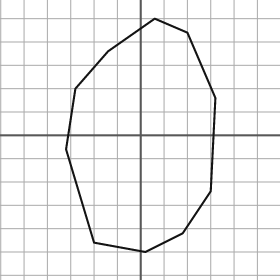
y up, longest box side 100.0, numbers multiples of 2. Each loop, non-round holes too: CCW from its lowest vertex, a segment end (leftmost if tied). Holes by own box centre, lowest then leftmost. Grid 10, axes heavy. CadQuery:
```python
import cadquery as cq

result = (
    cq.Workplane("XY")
    .moveTo(2.0, -50.0)
    .lineTo(18.0, -42.0)
    .lineTo(30.0, -24.0)
    .lineTo(32.0, 16.0)
    .lineTo(20.0, 44.0)
    .lineTo(6.0, 50.0)
    .lineTo(-14.0, 36.0)
    .lineTo(-28.0, 20.0)
    .lineTo(-32.0, -6.0)
    .lineTo(-20.0, -46.0)
    .close()
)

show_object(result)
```